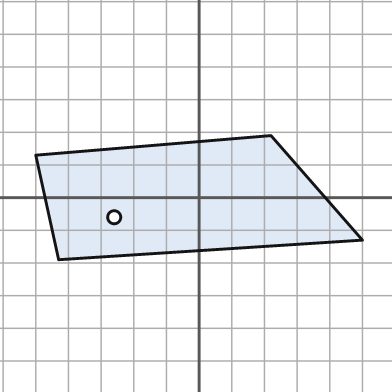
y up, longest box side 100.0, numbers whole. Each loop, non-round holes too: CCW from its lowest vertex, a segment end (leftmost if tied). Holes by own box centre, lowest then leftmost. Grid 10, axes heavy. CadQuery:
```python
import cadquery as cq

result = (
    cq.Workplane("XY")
    .moveTo(-43.0, -19.0)
    .lineTo(50.0, -13.0)
    .lineTo(22.0, 19.0)
    .lineTo(-50.0, 13.0)
    .close()
    .moveTo(-26.0, -6.0)
    .circle(2.0)
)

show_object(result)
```